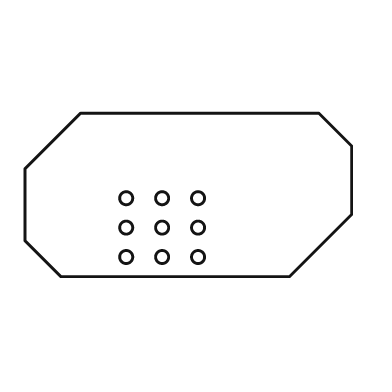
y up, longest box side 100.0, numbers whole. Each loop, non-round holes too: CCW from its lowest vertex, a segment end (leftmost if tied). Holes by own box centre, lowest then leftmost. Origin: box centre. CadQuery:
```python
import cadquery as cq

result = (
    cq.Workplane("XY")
    .moveTo(-39.0, -25.0)
    .lineTo(31.0, -25.0)
    .lineTo(50.0, -6.0)
    .lineTo(50.0, 15.0)
    .lineTo(40.0, 25.0)
    .lineTo(-33.0, 25.0)
    .lineTo(-50.0, 8.0)
    .lineTo(-50.0, -14.0)
    .close()
    .moveTo(-19.0, -19.0)
    .circle(2.0)
    .moveTo(-8.0, -19.0)
    .circle(2.0)
    .moveTo(3.0, -19.0)
    .circle(2.0)
    .moveTo(-19.0, -10.0)
    .circle(2.0)
    .moveTo(-8.0, -10.0)
    .circle(2.0)
    .moveTo(3.0, -10.0)
    .circle(2.0)
    .moveTo(-19.0, -1.0)
    .circle(2.0)
    .moveTo(-8.0, -1.0)
    .circle(2.0)
    .moveTo(3.0, -1.0)
    .circle(2.0)
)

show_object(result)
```